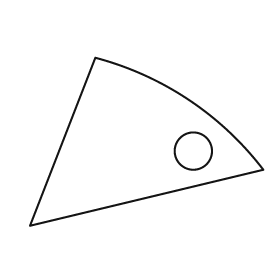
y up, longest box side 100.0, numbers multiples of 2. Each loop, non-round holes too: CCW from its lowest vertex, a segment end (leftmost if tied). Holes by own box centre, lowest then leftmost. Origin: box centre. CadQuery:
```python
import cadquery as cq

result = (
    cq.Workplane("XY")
    .moveTo(-50.0, -36.0)
    .lineTo(50.0, -12.0)
    .threePointArc((18.0, 18.0), (-22.0, 36.0))
    .close()
    .moveTo(20.0, -4.0)
    .circle(8.0)
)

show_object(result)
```